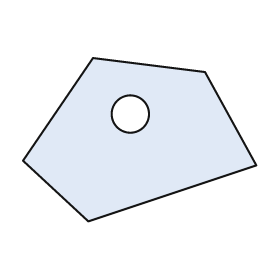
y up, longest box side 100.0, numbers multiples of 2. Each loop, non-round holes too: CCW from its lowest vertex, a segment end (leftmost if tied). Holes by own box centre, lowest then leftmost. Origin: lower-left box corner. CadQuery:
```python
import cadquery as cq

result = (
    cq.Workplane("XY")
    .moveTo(28.0, 0.0)
    .lineTo(100.0, 24.0)
    .lineTo(78.0, 64.0)
    .lineTo(30.0, 70.0)
    .lineTo(0.0, 26.0)
    .close()
    .moveTo(46.0, 46.0)
    .circle(8.0)
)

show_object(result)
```